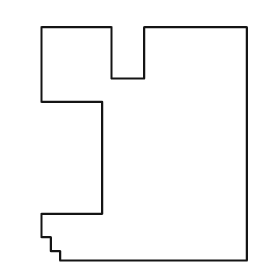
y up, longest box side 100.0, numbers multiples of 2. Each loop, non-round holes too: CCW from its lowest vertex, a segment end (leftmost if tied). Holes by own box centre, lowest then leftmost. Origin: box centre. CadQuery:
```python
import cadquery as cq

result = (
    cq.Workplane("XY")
    .moveTo(-36.0, -50.0)
    .lineTo(44.0, -50.0)
    .lineTo(44.0, 50.0)
    .lineTo(0.0, 50.0)
    .lineTo(0.0, 28.0)
    .lineTo(-14.0, 28.0)
    .lineTo(-14.0, 50.0)
    .lineTo(-44.0, 50.0)
    .lineTo(-44.0, 18.0)
    .lineTo(-18.0, 18.0)
    .lineTo(-18.0, -30.0)
    .lineTo(-44.0, -30.0)
    .lineTo(-44.0, -40.0)
    .lineTo(-40.0, -40.0)
    .lineTo(-40.0, -46.0)
    .lineTo(-36.0, -46.0)
    .close()
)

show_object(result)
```